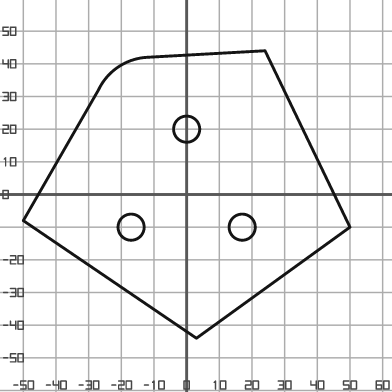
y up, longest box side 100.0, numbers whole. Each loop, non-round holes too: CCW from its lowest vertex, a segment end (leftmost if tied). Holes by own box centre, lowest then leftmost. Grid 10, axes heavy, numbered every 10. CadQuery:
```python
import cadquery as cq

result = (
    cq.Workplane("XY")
    .moveTo(3.0, -44.0)
    .lineTo(50.0, -10.0)
    .lineTo(24.0, 44.0)
    .lineTo(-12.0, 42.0)
    .threePointArc((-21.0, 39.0), (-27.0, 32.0))
    .lineTo(-50.0, -8.0)
    .close()
    .moveTo(-17.0, -10.0)
    .circle(4.0)
    .moveTo(17.0, -10.0)
    .circle(4.0)
    .moveTo(0.0, 20.0)
    .circle(4.0)
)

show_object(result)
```